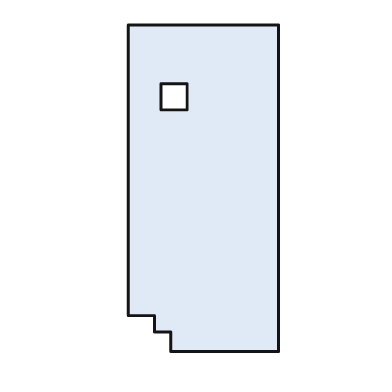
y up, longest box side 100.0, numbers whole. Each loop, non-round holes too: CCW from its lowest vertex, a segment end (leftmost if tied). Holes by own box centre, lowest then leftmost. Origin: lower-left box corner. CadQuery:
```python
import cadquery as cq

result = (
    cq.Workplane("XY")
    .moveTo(13.0, 0.0)
    .lineTo(46.0, 0.0)
    .lineTo(46.0, 100.0)
    .lineTo(0.0, 100.0)
    .lineTo(0.0, 11.0)
    .lineTo(8.0, 11.0)
    .lineTo(8.0, 6.0)
    .lineTo(13.0, 6.0)
    .close()
    .moveTo(10.0, 74.0)
    .lineTo(18.0, 74.0)
    .lineTo(18.0, 82.0)
    .lineTo(10.0, 82.0)
    .close()
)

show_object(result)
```